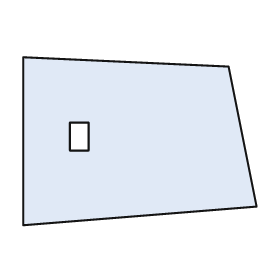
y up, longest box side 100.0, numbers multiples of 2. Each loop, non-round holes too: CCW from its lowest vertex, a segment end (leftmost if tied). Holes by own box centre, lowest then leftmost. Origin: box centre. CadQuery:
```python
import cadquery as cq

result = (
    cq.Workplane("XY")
    .moveTo(-50.0, -36.0)
    .lineTo(50.0, -28.0)
    .lineTo(38.0, 32.0)
    .lineTo(-50.0, 36.0)
    .close()
    .moveTo(-30.0, -4.0)
    .lineTo(-22.0, -4.0)
    .lineTo(-22.0, 8.0)
    .lineTo(-30.0, 8.0)
    .close()
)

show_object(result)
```